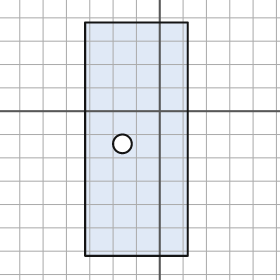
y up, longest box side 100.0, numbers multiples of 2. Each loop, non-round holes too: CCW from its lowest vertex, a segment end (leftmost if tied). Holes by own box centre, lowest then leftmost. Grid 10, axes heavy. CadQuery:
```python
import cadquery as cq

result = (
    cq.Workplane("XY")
    .moveTo(-32.0, -62.0)
    .lineTo(12.0, -62.0)
    .lineTo(12.0, 38.0)
    .lineTo(-32.0, 38.0)
    .close()
    .moveTo(-16.0, -14.0)
    .circle(4.0)
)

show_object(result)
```